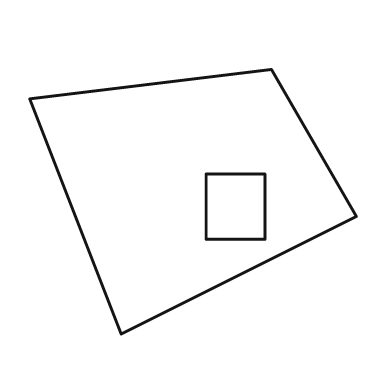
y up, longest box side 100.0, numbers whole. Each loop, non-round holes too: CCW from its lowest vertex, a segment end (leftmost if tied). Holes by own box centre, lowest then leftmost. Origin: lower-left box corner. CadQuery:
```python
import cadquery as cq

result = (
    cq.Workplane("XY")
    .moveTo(28.0, 0.0)
    .lineTo(100.0, 36.0)
    .lineTo(74.0, 81.0)
    .lineTo(0.0, 72.0)
    .close()
    .moveTo(54.0, 29.0)
    .lineTo(72.0, 29.0)
    .lineTo(72.0, 49.0)
    .lineTo(54.0, 49.0)
    .close()
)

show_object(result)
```